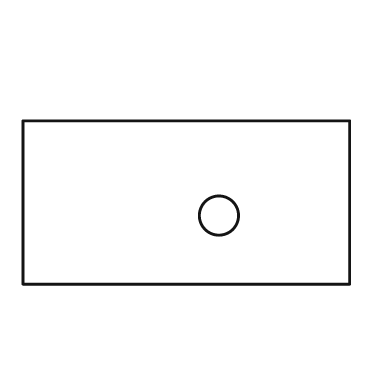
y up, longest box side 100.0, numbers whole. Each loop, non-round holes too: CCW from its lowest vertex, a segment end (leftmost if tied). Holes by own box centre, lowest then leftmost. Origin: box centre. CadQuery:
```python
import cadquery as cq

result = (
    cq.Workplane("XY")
    .moveTo(-50.0, -25.0)
    .lineTo(50.0, -25.0)
    .lineTo(50.0, 25.0)
    .lineTo(-50.0, 25.0)
    .close()
    .moveTo(10.0, -4.0)
    .circle(6.0)
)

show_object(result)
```